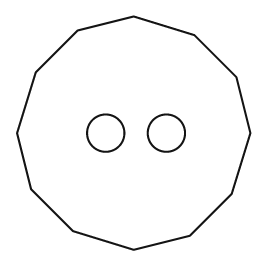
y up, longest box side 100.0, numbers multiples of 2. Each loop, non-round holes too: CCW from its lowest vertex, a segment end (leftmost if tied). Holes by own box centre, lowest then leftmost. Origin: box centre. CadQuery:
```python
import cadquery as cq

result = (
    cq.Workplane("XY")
    .moveTo(0.0, -50.0)
    .lineTo(24.0, -44.0)
    .lineTo(42.0, -26.0)
    .lineTo(50.0, 0.0)
    .lineTo(44.0, 24.0)
    .lineTo(26.0, 42.0)
    .lineTo(0.0, 50.0)
    .lineTo(-24.0, 44.0)
    .lineTo(-42.0, 26.0)
    .lineTo(-50.0, 0.0)
    .lineTo(-44.0, -24.0)
    .lineTo(-26.0, -42.0)
    .close()
    .moveTo(-12.0, 0.0)
    .circle(8.0)
    .moveTo(14.0, 0.0)
    .circle(8.0)
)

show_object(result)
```